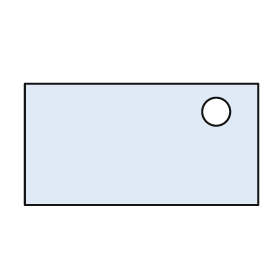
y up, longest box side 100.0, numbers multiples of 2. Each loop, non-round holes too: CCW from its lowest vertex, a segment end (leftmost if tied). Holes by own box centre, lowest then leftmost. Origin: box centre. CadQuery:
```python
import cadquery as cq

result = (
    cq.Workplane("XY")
    .moveTo(-50.0, -26.0)
    .lineTo(50.0, -26.0)
    .lineTo(50.0, 26.0)
    .lineTo(-50.0, 26.0)
    .close()
    .moveTo(32.0, 14.0)
    .circle(6.0)
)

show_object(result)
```